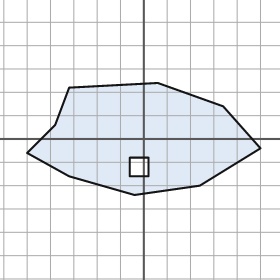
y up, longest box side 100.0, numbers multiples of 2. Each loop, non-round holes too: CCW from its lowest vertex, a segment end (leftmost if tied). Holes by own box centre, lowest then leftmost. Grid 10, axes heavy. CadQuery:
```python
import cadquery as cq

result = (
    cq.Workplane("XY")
    .moveTo(-4.0, -24.0)
    .lineTo(24.0, -20.0)
    .lineTo(50.0, -4.0)
    .lineTo(34.0, 14.0)
    .lineTo(6.0, 24.0)
    .lineTo(-32.0, 22.0)
    .lineTo(-38.0, 6.0)
    .lineTo(-50.0, -6.0)
    .lineTo(-32.0, -16.0)
    .close()
    .moveTo(-6.0, -16.0)
    .lineTo(2.0, -16.0)
    .lineTo(2.0, -8.0)
    .lineTo(-6.0, -8.0)
    .close()
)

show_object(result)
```